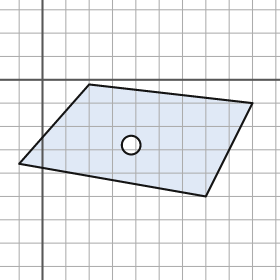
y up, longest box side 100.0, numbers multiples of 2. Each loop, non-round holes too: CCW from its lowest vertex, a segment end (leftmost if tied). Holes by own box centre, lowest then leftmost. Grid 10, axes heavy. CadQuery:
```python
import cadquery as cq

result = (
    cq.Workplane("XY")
    .moveTo(70.0, -50.0)
    .lineTo(90.0, -10.0)
    .lineTo(20.0, -2.0)
    .lineTo(-10.0, -36.0)
    .close()
    .moveTo(38.0, -28.0)
    .circle(4.0)
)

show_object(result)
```